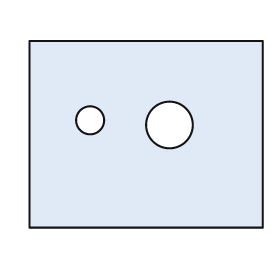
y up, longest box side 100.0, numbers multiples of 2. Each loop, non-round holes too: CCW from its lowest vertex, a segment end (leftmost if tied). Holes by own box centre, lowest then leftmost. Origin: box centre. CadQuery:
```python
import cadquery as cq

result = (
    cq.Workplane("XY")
    .moveTo(-50.0, -40.0)
    .lineTo(50.0, -40.0)
    .lineTo(50.0, 40.0)
    .lineTo(-50.0, 40.0)
    .close()
    .moveTo(10.0, 4.0)
    .circle(10.0)
    .moveTo(-24.0, 6.0)
    .circle(6.0)
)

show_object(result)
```